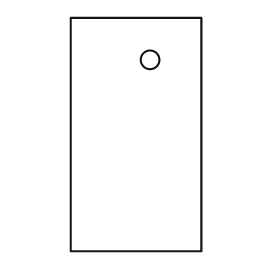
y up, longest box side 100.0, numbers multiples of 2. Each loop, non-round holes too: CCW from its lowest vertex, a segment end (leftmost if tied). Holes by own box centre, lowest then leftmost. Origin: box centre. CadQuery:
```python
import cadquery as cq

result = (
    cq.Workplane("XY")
    .moveTo(-28.0, -50.0)
    .lineTo(28.0, -50.0)
    .lineTo(28.0, 50.0)
    .lineTo(-28.0, 50.0)
    .close()
    .moveTo(6.0, 32.0)
    .circle(4.0)
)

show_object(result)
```